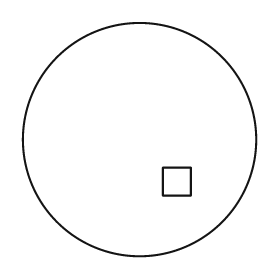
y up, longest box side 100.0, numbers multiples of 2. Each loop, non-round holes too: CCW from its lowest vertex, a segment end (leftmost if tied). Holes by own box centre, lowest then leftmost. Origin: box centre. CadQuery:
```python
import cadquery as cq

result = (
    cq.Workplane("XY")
    .moveTo(0.0, 0.0)
    .circle(50.0)
    .moveTo(10.0, -24.0)
    .lineTo(22.0, -24.0)
    .lineTo(22.0, -12.0)
    .lineTo(10.0, -12.0)
    .close()
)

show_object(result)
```